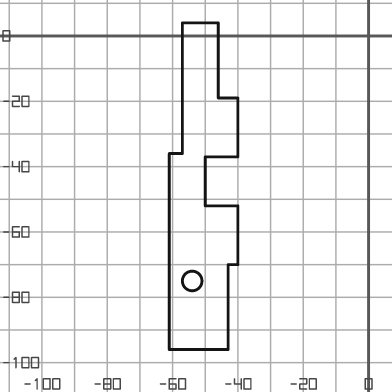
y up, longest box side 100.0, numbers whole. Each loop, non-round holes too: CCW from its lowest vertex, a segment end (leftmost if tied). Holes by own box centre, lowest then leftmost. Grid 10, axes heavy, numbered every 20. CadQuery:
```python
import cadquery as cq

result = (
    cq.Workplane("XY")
    .moveTo(-61.0, -96.0)
    .lineTo(-43.0, -96.0)
    .lineTo(-43.0, -70.0)
    .lineTo(-40.0, -70.0)
    .lineTo(-40.0, -52.0)
    .lineTo(-50.0, -52.0)
    .lineTo(-50.0, -37.0)
    .lineTo(-40.0, -37.0)
    .lineTo(-40.0, -19.0)
    .lineTo(-46.0, -19.0)
    .lineTo(-46.0, 4.0)
    .lineTo(-57.0, 4.0)
    .lineTo(-57.0, -36.0)
    .lineTo(-61.0, -36.0)
    .close()
    .moveTo(-54.0, -75.0)
    .circle(3.0)
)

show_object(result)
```